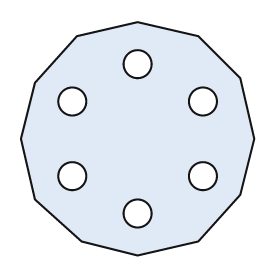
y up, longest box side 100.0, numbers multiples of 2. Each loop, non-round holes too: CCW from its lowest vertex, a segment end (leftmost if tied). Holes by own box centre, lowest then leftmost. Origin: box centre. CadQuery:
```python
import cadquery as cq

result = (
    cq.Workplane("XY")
    .moveTo(0.0, -50.0)
    .lineTo(26.0, -44.0)
    .lineTo(44.0, -24.0)
    .lineTo(50.0, 0.0)
    .lineTo(44.0, 26.0)
    .lineTo(26.0, 44.0)
    .lineTo(0.0, 50.0)
    .lineTo(-26.0, 44.0)
    .lineTo(-44.0, 24.0)
    .lineTo(-50.0, 0.0)
    .lineTo(-44.0, -26.0)
    .lineTo(-24.0, -44.0)
    .close()
    .moveTo(0.0, -32.0)
    .circle(6.0)
    .moveTo(-28.0, -16.0)
    .circle(6.0)
    .moveTo(28.0, -16.0)
    .circle(6.0)
    .moveTo(-28.0, 16.0)
    .circle(6.0)
    .moveTo(28.0, 16.0)
    .circle(6.0)
    .moveTo(0.0, 32.0)
    .circle(6.0)
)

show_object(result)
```